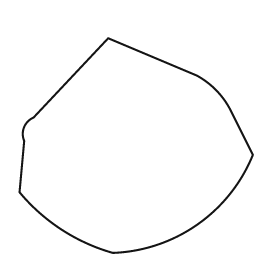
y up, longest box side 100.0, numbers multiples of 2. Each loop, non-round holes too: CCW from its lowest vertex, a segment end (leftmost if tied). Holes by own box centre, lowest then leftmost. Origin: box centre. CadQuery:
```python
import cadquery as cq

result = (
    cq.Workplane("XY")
    .moveTo(-10.0, -46.0)
    .threePointArc((26.0, -34.0), (50.0, -4.0))
    .lineTo(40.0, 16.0)
    .threePointArc((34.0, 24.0), (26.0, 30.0))
    .lineTo(-12.0, 46.0)
    .lineTo(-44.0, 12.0)
    .threePointArc((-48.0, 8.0), (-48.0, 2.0))
    .lineTo(-50.0, -20.0)
    .threePointArc((-32.0, -36.0), (-10.0, -46.0))
    .close()
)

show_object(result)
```